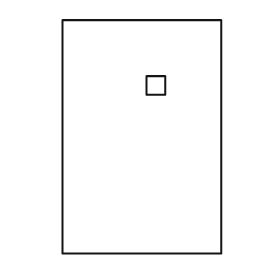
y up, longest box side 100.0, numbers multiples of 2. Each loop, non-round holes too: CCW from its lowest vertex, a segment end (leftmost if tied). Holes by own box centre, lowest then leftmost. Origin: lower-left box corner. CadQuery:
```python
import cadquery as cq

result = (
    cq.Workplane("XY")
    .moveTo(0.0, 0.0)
    .lineTo(68.0, 0.0)
    .lineTo(68.0, 100.0)
    .lineTo(0.0, 100.0)
    .close()
    .moveTo(36.0, 68.0)
    .lineTo(44.0, 68.0)
    .lineTo(44.0, 76.0)
    .lineTo(36.0, 76.0)
    .close()
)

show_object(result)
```